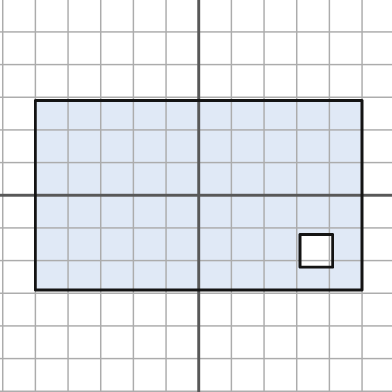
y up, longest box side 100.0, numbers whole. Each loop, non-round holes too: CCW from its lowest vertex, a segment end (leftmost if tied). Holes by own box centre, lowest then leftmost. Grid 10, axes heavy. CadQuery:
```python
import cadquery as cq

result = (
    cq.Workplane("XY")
    .moveTo(-50.0, -29.0)
    .lineTo(50.0, -29.0)
    .lineTo(50.0, 29.0)
    .lineTo(-50.0, 29.0)
    .close()
    .moveTo(31.0, -22.0)
    .lineTo(41.0, -22.0)
    .lineTo(41.0, -12.0)
    .lineTo(31.0, -12.0)
    .close()
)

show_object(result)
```